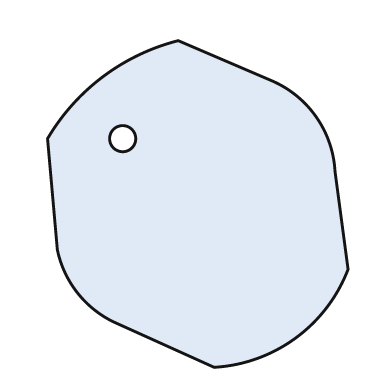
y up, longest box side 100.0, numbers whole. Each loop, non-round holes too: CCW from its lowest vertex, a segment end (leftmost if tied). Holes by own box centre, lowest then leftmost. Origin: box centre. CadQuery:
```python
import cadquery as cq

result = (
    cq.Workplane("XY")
    .moveTo(5.0, -50.0)
    .threePointArc((30.0, -41.0), (46.0, -20.0))
    .lineTo(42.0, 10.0)
    .threePointArc((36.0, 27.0), (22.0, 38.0))
    .lineTo(-6.0, 50.0)
    .threePointArc((-29.0, 39.0), (-46.0, 20.0))
    .lineTo(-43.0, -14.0)
    .threePointArc((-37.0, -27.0), (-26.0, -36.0))
    .close()
    .moveTo(-23.0, 20.0)
    .circle(4.0)
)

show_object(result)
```